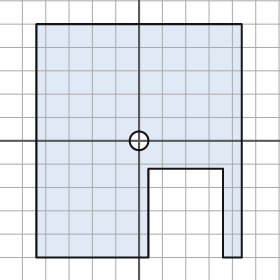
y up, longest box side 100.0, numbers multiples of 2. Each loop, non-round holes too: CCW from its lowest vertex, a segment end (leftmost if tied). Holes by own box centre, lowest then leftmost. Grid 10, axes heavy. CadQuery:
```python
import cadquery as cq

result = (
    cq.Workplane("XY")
    .moveTo(-44.0, -50.0)
    .lineTo(4.0, -50.0)
    .lineTo(4.0, -12.0)
    .lineTo(36.0, -12.0)
    .lineTo(36.0, -50.0)
    .lineTo(44.0, -50.0)
    .lineTo(44.0, 50.0)
    .lineTo(-44.0, 50.0)
    .close()
    .moveTo(0.0, 0.0)
    .circle(4.0)
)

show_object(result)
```